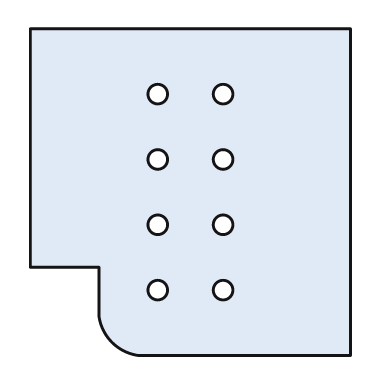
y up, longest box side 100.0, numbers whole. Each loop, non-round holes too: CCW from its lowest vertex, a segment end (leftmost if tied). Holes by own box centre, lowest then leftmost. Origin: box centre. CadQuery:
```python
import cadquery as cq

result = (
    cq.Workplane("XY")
    .moveTo(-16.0, -50.0)
    .lineTo(49.0, -50.0)
    .lineTo(49.0, 50.0)
    .lineTo(-49.0, 50.0)
    .lineTo(-49.0, -23.0)
    .lineTo(-28.0, -23.0)
    .lineTo(-28.0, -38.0)
    .threePointArc((-24.0, -46.0), (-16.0, -50.0))
    .close()
    .moveTo(-10.0, -30.0)
    .circle(3.0)
    .moveTo(10.0, -30.0)
    .circle(3.0)
    .moveTo(-10.0, -10.0)
    .circle(3.0)
    .moveTo(10.0, -10.0)
    .circle(3.0)
    .moveTo(-10.0, 10.0)
    .circle(3.0)
    .moveTo(10.0, 10.0)
    .circle(3.0)
    .moveTo(-10.0, 30.0)
    .circle(3.0)
    .moveTo(10.0, 30.0)
    .circle(3.0)
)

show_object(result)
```